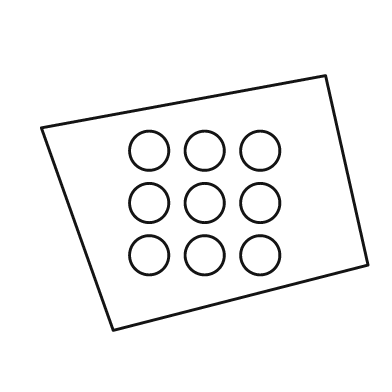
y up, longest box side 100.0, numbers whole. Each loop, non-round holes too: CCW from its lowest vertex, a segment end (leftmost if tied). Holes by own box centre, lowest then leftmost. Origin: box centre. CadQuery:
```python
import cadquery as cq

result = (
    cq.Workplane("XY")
    .moveTo(-28.0, -39.0)
    .lineTo(50.0, -19.0)
    .lineTo(37.0, 39.0)
    .lineTo(-50.0, 23.0)
    .close()
    .moveTo(-17.0, -16.0)
    .circle(6.0)
    .moveTo(0.0, -16.0)
    .circle(6.0)
    .moveTo(17.0, -16.0)
    .circle(6.0)
    .moveTo(-17.0, 0.0)
    .circle(6.0)
    .moveTo(0.0, 0.0)
    .circle(6.0)
    .moveTo(17.0, 0.0)
    .circle(6.0)
    .moveTo(-17.0, 16.0)
    .circle(6.0)
    .moveTo(0.0, 16.0)
    .circle(6.0)
    .moveTo(17.0, 16.0)
    .circle(6.0)
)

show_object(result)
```